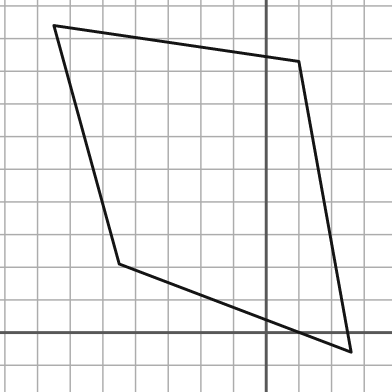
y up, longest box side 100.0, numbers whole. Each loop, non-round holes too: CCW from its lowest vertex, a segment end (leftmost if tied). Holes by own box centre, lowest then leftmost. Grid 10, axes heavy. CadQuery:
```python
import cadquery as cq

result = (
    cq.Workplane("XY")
    .moveTo(26.0, -6.0)
    .lineTo(10.0, 83.0)
    .lineTo(-65.0, 94.0)
    .lineTo(-45.0, 21.0)
    .close()
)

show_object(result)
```